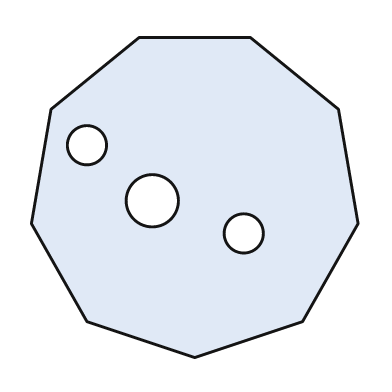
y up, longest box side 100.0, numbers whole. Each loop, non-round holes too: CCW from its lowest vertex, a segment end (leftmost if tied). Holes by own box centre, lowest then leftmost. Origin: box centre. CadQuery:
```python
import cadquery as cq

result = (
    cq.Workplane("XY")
    .moveTo(0.0, -49.0)
    .lineTo(33.0, -38.0)
    .lineTo(50.0, -8.0)
    .lineTo(44.0, 27.0)
    .lineTo(17.0, 49.0)
    .lineTo(-17.0, 49.0)
    .lineTo(-44.0, 27.0)
    .lineTo(-50.0, -8.0)
    .lineTo(-33.0, -38.0)
    .close()
    .moveTo(15.0, -11.0)
    .circle(6.0)
    .moveTo(-13.0, -1.0)
    .circle(8.0)
    .moveTo(-33.0, 16.0)
    .circle(6.0)
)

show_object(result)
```